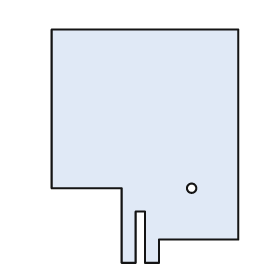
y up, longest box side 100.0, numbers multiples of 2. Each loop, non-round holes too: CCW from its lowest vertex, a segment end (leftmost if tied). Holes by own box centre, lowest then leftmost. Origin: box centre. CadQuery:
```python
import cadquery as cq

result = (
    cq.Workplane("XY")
    .moveTo(-10.0, -50.0)
    .lineTo(-4.0, -50.0)
    .lineTo(-4.0, -28.0)
    .lineTo(0.0, -28.0)
    .lineTo(0.0, -50.0)
    .lineTo(6.0, -50.0)
    .lineTo(6.0, -40.0)
    .lineTo(40.0, -40.0)
    .lineTo(40.0, 50.0)
    .lineTo(-40.0, 50.0)
    .lineTo(-40.0, -18.0)
    .lineTo(-10.0, -18.0)
    .close()
    .moveTo(20.0, -18.0)
    .circle(2.0)
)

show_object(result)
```